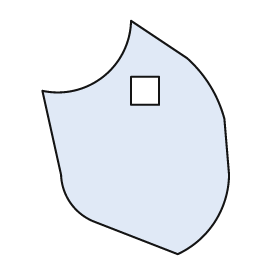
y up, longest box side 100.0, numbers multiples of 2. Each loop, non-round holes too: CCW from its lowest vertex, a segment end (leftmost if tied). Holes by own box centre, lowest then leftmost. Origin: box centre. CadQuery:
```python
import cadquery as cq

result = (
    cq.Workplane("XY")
    .moveTo(18.0, -50.0)
    .threePointArc((34.0, -36.0), (40.0, -16.0))
    .lineTo(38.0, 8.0)
    .threePointArc((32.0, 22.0), (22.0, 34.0))
    .lineTo(-2.0, 50.0)
    .threePointArc((-14.0, 26.0), (-40.0, 20.0))
    .lineTo(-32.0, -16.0)
    .threePointArc((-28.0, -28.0), (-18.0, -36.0))
    .close()
    .moveTo(-2.0, 14.0)
    .lineTo(10.0, 14.0)
    .lineTo(10.0, 26.0)
    .lineTo(-2.0, 26.0)
    .close()
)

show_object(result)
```